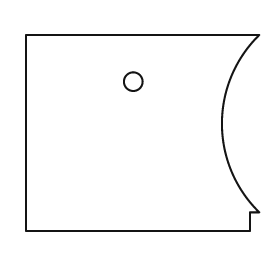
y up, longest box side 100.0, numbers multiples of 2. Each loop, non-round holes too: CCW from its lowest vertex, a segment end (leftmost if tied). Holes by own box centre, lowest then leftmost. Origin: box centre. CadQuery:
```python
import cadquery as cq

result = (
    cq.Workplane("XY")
    .moveTo(-50.0, -42.0)
    .lineTo(46.0, -42.0)
    .lineTo(46.0, -34.0)
    .lineTo(50.0, -34.0)
    .threePointArc((34.0, 4.0), (50.0, 42.0))
    .lineTo(-50.0, 42.0)
    .close()
    .moveTo(-4.0, 22.0)
    .circle(4.0)
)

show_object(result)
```